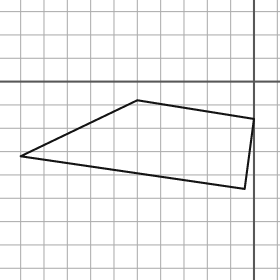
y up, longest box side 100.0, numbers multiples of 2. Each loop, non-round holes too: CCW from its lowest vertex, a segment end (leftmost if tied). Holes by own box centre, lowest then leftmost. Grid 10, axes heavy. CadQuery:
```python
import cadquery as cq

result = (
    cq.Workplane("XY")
    .moveTo(-4.0, -46.0)
    .lineTo(0.0, -16.0)
    .lineTo(-50.0, -8.0)
    .lineTo(-100.0, -32.0)
    .close()
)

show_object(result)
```